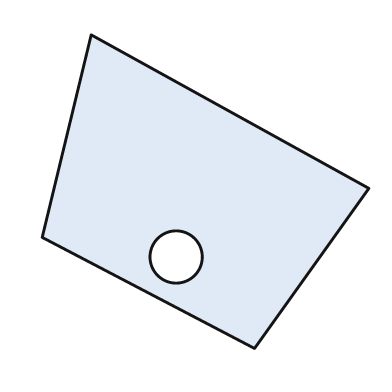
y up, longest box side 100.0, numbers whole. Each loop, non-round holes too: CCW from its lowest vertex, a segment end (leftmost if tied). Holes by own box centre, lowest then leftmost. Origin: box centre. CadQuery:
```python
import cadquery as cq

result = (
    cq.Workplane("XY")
    .moveTo(15.0, -48.0)
    .lineTo(50.0, 1.0)
    .lineTo(-35.0, 48.0)
    .lineTo(-50.0, -14.0)
    .close()
    .moveTo(-9.0, -20.0)
    .circle(8.0)
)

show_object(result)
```